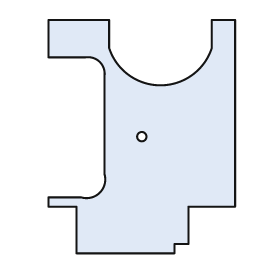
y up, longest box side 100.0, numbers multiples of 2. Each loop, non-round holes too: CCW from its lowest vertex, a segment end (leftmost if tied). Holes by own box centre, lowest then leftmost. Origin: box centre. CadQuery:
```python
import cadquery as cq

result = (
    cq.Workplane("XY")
    .moveTo(-28.0, -50.0)
    .lineTo(14.0, -50.0)
    .lineTo(14.0, -46.0)
    .lineTo(20.0, -46.0)
    .lineTo(20.0, -30.0)
    .lineTo(40.0, -30.0)
    .lineTo(40.0, 50.0)
    .lineTo(30.0, 50.0)
    .lineTo(30.0, 38.0)
    .threePointArc((8.0, 22.0), (-14.0, 38.0))
    .lineTo(-14.0, 50.0)
    .lineTo(-40.0, 50.0)
    .lineTo(-40.0, 34.0)
    .lineTo(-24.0, 34.0)
    .threePointArc((-18.0, 32.0), (-16.0, 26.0))
    .lineTo(-16.0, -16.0)
    .threePointArc((-18.0, -24.0), (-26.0, -26.0))
    .lineTo(-40.0, -26.0)
    .lineTo(-40.0, -30.0)
    .lineTo(-28.0, -30.0)
    .close()
    .moveTo(0.0, 0.0)
    .circle(2.0)
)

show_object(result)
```